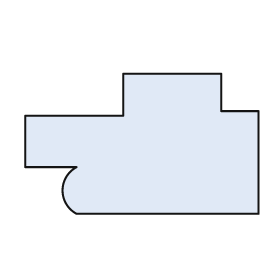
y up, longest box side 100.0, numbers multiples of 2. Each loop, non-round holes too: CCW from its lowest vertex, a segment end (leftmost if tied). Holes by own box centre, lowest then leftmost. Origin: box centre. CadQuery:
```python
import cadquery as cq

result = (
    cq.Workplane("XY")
    .moveTo(-28.0, -30.0)
    .lineTo(50.0, -30.0)
    .lineTo(50.0, 14.0)
    .lineTo(34.0, 14.0)
    .lineTo(34.0, 30.0)
    .lineTo(-8.0, 30.0)
    .lineTo(-8.0, 12.0)
    .lineTo(-50.0, 12.0)
    .lineTo(-50.0, -10.0)
    .lineTo(-28.0, -10.0)
    .threePointArc((-34.0, -20.0), (-28.0, -30.0))
    .close()
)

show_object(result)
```